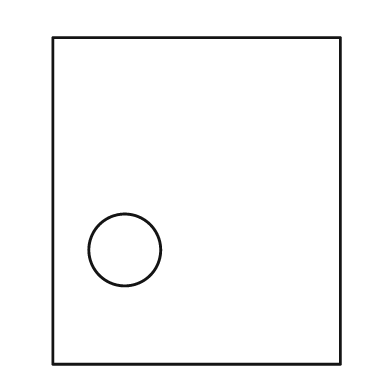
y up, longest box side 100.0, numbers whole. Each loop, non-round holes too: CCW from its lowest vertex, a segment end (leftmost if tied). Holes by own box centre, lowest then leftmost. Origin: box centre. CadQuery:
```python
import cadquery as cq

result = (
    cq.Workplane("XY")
    .moveTo(-44.0, -50.0)
    .lineTo(44.0, -50.0)
    .lineTo(44.0, 50.0)
    .lineTo(-44.0, 50.0)
    .close()
    .moveTo(-22.0, -15.0)
    .circle(11.0)
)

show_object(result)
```